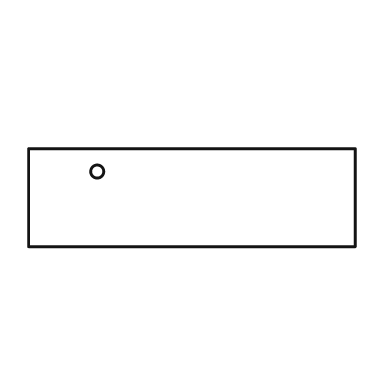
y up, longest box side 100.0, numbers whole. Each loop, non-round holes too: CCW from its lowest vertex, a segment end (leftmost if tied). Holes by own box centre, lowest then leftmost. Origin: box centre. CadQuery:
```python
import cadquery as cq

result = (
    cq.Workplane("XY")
    .moveTo(-50.0, -15.0)
    .lineTo(50.0, -15.0)
    .lineTo(50.0, 15.0)
    .lineTo(-50.0, 15.0)
    .close()
    .moveTo(-29.0, 8.0)
    .circle(2.0)
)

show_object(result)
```